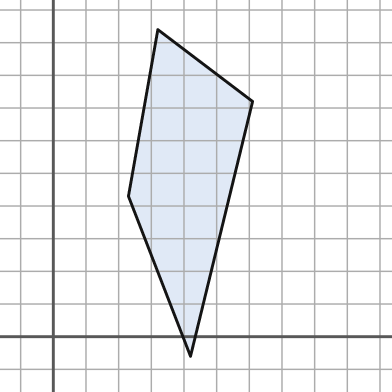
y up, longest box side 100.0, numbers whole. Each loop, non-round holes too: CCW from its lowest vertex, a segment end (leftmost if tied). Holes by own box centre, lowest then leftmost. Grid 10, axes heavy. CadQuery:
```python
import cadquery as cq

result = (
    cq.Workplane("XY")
    .moveTo(42.0, -6.0)
    .lineTo(61.0, 72.0)
    .lineTo(32.0, 94.0)
    .lineTo(23.0, 43.0)
    .close()
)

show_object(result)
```